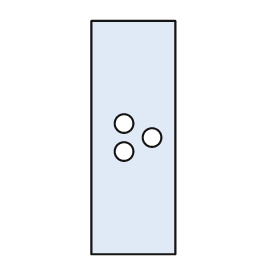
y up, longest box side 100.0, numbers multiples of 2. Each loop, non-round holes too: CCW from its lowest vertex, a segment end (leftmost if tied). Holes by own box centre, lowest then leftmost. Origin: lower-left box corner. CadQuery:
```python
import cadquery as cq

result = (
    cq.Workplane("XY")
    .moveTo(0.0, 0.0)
    .lineTo(36.0, 0.0)
    .lineTo(36.0, 100.0)
    .lineTo(0.0, 100.0)
    .close()
    .moveTo(14.0, 44.0)
    .circle(4.0)
    .moveTo(26.0, 50.0)
    .circle(4.0)
    .moveTo(14.0, 56.0)
    .circle(4.0)
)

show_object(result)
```